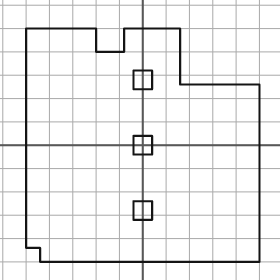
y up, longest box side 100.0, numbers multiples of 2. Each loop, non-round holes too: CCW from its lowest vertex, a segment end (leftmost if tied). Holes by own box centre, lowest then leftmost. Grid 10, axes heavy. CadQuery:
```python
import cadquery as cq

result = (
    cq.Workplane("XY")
    .moveTo(-44.0, -50.0)
    .lineTo(50.0, -50.0)
    .lineTo(50.0, 26.0)
    .lineTo(16.0, 26.0)
    .lineTo(16.0, 50.0)
    .lineTo(-8.0, 50.0)
    .lineTo(-8.0, 40.0)
    .lineTo(-20.0, 40.0)
    .lineTo(-20.0, 50.0)
    .lineTo(-50.0, 50.0)
    .lineTo(-50.0, -44.0)
    .lineTo(-44.0, -44.0)
    .close()
    .moveTo(-4.0, -32.0)
    .lineTo(4.0, -32.0)
    .lineTo(4.0, -24.0)
    .lineTo(-4.0, -24.0)
    .close()
    .moveTo(-4.0, -4.0)
    .lineTo(4.0, -4.0)
    .lineTo(4.0, 4.0)
    .lineTo(-4.0, 4.0)
    .close()
    .moveTo(-4.0, 24.0)
    .lineTo(4.0, 24.0)
    .lineTo(4.0, 32.0)
    .lineTo(-4.0, 32.0)
    .close()
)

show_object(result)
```